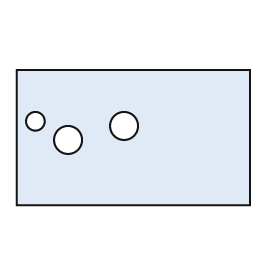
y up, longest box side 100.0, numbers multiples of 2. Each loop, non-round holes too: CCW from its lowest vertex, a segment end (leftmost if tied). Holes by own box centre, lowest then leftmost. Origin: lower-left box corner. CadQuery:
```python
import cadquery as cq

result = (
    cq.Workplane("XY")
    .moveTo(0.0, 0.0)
    .lineTo(100.0, 0.0)
    .lineTo(100.0, 58.0)
    .lineTo(0.0, 58.0)
    .close()
    .moveTo(22.0, 28.0)
    .circle(6.0)
    .moveTo(46.0, 34.0)
    .circle(6.0)
    .moveTo(8.0, 36.0)
    .circle(4.0)
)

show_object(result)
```